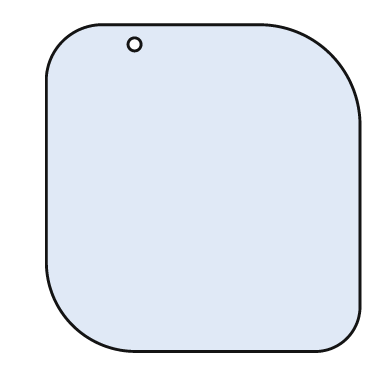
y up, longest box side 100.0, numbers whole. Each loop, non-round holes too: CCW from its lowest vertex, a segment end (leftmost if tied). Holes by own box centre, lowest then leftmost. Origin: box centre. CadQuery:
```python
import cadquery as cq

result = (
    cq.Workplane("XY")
    .moveTo(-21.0, -50.0)
    .lineTo(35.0, -50.0)
    .threePointArc((44.0, -46.0), (48.0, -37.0))
    .lineTo(48.0, 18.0)
    .threePointArc((39.0, 41.0), (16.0, 50.0))
    .lineTo(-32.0, 50.0)
    .threePointArc((-43.0, 45.0), (-48.0, 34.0))
    .lineTo(-48.0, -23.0)
    .threePointArc((-40.0, -42.0), (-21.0, -50.0))
    .close()
    .moveTo(-21.0, 44.0)
    .circle(2.0)
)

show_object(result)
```